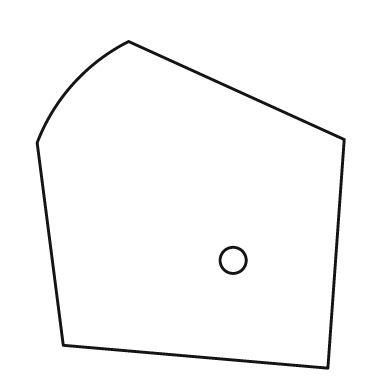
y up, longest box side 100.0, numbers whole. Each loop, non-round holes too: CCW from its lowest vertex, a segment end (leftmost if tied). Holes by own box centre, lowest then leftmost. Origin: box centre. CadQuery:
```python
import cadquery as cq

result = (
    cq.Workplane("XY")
    .moveTo(42.0, -50.0)
    .lineTo(47.0, 20.0)
    .lineTo(-19.0, 50.0)
    .threePointArc((-36.0, 37.0), (-47.0, 19.0))
    .lineTo(-39.0, -43.0)
    .close()
    .moveTo(13.0, -17.0)
    .circle(4.0)
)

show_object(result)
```